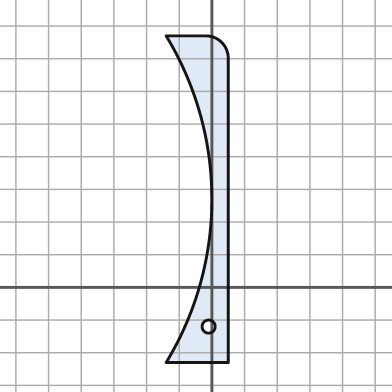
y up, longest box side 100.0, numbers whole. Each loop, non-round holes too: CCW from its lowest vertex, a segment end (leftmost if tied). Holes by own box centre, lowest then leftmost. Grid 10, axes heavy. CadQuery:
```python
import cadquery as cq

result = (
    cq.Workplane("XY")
    .moveTo(-14.0, -23.0)
    .lineTo(5.0, -23.0)
    .lineTo(5.0, 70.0)
    .threePointArc((3.0, 75.0), (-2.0, 77.0))
    .lineTo(-14.0, 77.0)
    .threePointArc((0.0, 27.0), (-14.0, -23.0))
    .close()
    .moveTo(-1.0, -12.0)
    .circle(2.0)
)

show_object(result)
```